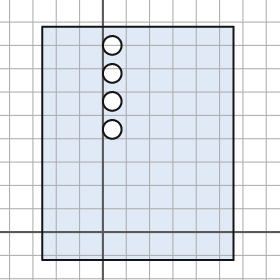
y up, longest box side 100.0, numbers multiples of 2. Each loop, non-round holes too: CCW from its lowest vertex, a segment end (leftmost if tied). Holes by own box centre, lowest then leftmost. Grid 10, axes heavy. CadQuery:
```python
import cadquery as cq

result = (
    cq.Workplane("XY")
    .moveTo(-26.0, -12.0)
    .lineTo(56.0, -12.0)
    .lineTo(56.0, 88.0)
    .lineTo(-26.0, 88.0)
    .close()
    .moveTo(4.0, 44.0)
    .circle(4.0)
    .moveTo(4.0, 56.0)
    .circle(4.0)
    .moveTo(4.0, 68.0)
    .circle(4.0)
    .moveTo(4.0, 80.0)
    .circle(4.0)
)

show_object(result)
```